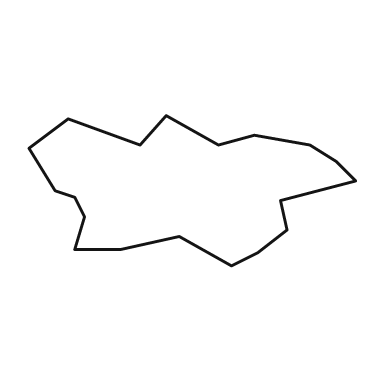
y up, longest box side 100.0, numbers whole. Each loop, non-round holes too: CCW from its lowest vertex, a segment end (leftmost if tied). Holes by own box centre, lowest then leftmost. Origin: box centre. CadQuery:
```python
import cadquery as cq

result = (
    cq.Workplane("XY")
    .moveTo(12.0, -23.0)
    .lineTo(20.0, -19.0)
    .lineTo(29.0, -12.0)
    .lineTo(27.0, -3.0)
    .lineTo(50.0, 3.0)
    .lineTo(44.0, 9.0)
    .lineTo(36.0, 14.0)
    .lineTo(19.0, 17.0)
    .lineTo(8.0, 14.0)
    .lineTo(-8.0, 23.0)
    .lineTo(-16.0, 14.0)
    .lineTo(-38.0, 22.0)
    .lineTo(-50.0, 13.0)
    .lineTo(-42.0, 0.0)
    .lineTo(-36.0, -2.0)
    .lineTo(-33.0, -8.0)
    .lineTo(-36.0, -18.0)
    .lineTo(-22.0, -18.0)
    .lineTo(-4.0, -14.0)
    .close()
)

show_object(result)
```